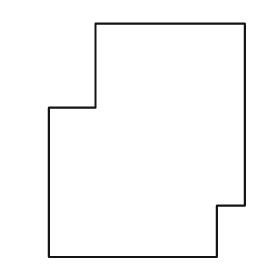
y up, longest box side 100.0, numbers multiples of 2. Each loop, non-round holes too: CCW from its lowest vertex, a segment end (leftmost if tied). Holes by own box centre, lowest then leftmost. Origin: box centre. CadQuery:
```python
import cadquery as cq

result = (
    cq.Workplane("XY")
    .moveTo(-42.0, -50.0)
    .lineTo(30.0, -50.0)
    .lineTo(30.0, -28.0)
    .lineTo(42.0, -28.0)
    .lineTo(42.0, 50.0)
    .lineTo(-22.0, 50.0)
    .lineTo(-22.0, 14.0)
    .lineTo(-42.0, 14.0)
    .close()
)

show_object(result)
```